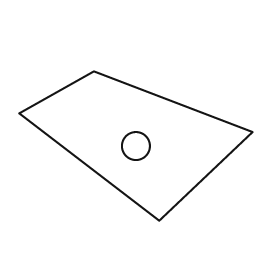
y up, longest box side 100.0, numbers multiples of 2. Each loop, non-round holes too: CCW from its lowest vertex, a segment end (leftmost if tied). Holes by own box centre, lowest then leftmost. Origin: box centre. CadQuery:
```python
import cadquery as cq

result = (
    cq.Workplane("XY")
    .moveTo(10.0, -32.0)
    .lineTo(50.0, 6.0)
    .lineTo(-18.0, 32.0)
    .lineTo(-50.0, 14.0)
    .close()
    .moveTo(0.0, 0.0)
    .circle(6.0)
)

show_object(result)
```